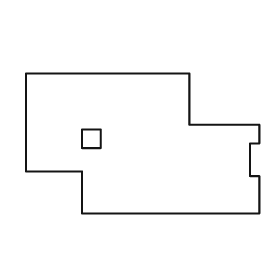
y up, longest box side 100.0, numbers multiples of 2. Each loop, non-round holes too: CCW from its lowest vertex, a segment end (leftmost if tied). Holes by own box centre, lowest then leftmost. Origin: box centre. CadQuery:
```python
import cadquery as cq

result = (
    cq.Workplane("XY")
    .moveTo(-26.0, -30.0)
    .lineTo(50.0, -30.0)
    .lineTo(50.0, -14.0)
    .lineTo(46.0, -14.0)
    .lineTo(46.0, 0.0)
    .lineTo(50.0, 0.0)
    .lineTo(50.0, 8.0)
    .lineTo(20.0, 8.0)
    .lineTo(20.0, 30.0)
    .lineTo(-50.0, 30.0)
    .lineTo(-50.0, -12.0)
    .lineTo(-26.0, -12.0)
    .close()
    .moveTo(-26.0, -2.0)
    .lineTo(-18.0, -2.0)
    .lineTo(-18.0, 6.0)
    .lineTo(-26.0, 6.0)
    .close()
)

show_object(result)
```